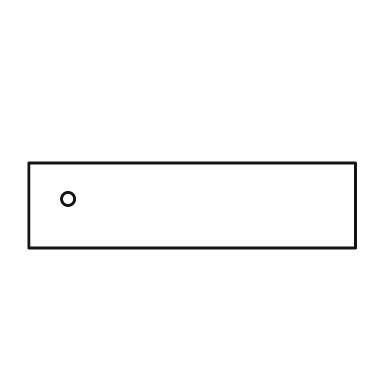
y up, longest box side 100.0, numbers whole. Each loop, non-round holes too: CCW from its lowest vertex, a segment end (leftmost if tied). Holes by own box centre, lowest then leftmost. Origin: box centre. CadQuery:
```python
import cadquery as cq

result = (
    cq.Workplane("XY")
    .moveTo(-50.0, -13.0)
    .lineTo(50.0, -13.0)
    .lineTo(50.0, 13.0)
    .lineTo(-50.0, 13.0)
    .close()
    .moveTo(-38.0, 2.0)
    .circle(2.0)
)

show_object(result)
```